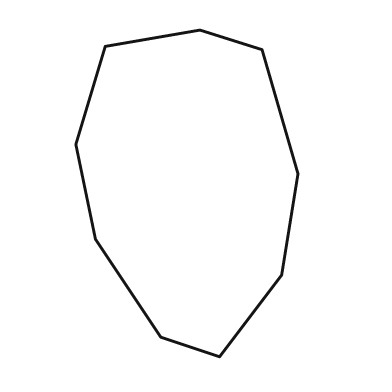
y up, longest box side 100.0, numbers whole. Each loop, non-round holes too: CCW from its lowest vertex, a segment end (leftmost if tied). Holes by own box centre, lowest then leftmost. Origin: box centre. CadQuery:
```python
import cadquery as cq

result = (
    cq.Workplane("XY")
    .moveTo(10.0, -50.0)
    .lineTo(29.0, -25.0)
    .lineTo(34.0, 6.0)
    .lineTo(23.0, 44.0)
    .lineTo(4.0, 50.0)
    .lineTo(-25.0, 45.0)
    .lineTo(-34.0, 15.0)
    .lineTo(-28.0, -14.0)
    .lineTo(-8.0, -44.0)
    .close()
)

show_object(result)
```